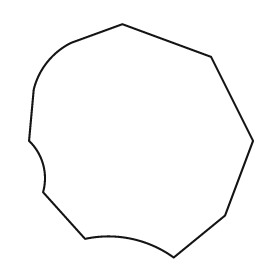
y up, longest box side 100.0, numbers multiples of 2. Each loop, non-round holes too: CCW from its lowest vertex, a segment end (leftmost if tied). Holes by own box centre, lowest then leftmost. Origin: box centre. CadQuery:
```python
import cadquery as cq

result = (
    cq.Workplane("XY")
    .moveTo(14.0, -50.0)
    .lineTo(36.0, -32.0)
    .lineTo(48.0, 0.0)
    .lineTo(30.0, 36.0)
    .lineTo(-8.0, 50.0)
    .lineTo(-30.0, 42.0)
    .threePointArc((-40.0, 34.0), (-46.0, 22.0))
    .lineTo(-48.0, 0.0)
    .threePointArc((-42.0, -10.0), (-42.0, -22.0))
    .lineTo(-24.0, -42.0)
    .threePointArc((-4.0, -42.0), (14.0, -50.0))
    .close()
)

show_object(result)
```